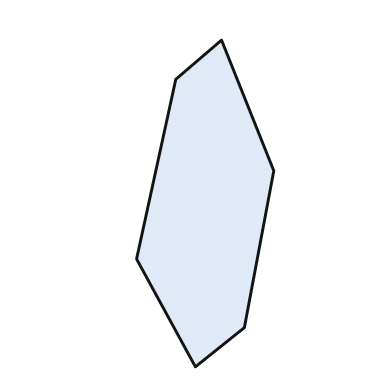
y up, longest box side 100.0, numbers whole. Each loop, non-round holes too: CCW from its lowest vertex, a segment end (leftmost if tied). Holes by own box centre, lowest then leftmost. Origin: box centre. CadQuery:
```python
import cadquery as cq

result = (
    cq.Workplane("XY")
    .moveTo(-3.0, -50.0)
    .lineTo(12.0, -38.0)
    .lineTo(21.0, 10.0)
    .lineTo(5.0, 50.0)
    .lineTo(-9.0, 38.0)
    .lineTo(-21.0, -17.0)
    .close()
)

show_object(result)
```